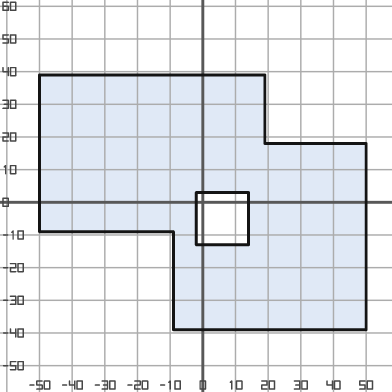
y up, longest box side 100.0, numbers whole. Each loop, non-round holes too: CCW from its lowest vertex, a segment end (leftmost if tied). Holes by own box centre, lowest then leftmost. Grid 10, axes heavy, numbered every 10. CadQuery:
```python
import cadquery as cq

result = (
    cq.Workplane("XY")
    .moveTo(-9.0, -39.0)
    .lineTo(50.0, -39.0)
    .lineTo(50.0, 18.0)
    .lineTo(19.0, 18.0)
    .lineTo(19.0, 39.0)
    .lineTo(-50.0, 39.0)
    .lineTo(-50.0, -9.0)
    .lineTo(-9.0, -9.0)
    .close()
    .moveTo(-2.0, -13.0)
    .lineTo(14.0, -13.0)
    .lineTo(14.0, 3.0)
    .lineTo(-2.0, 3.0)
    .close()
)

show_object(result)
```